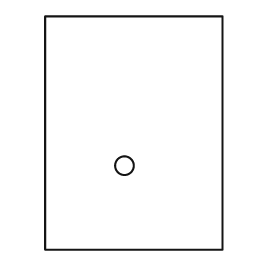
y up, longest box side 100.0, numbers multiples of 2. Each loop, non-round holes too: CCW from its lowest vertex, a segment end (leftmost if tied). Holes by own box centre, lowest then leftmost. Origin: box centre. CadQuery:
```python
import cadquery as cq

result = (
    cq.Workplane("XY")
    .moveTo(-38.0, -50.0)
    .lineTo(38.0, -50.0)
    .lineTo(38.0, 50.0)
    .lineTo(-38.0, 50.0)
    .close()
    .moveTo(-4.0, -14.0)
    .circle(4.0)
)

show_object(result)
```